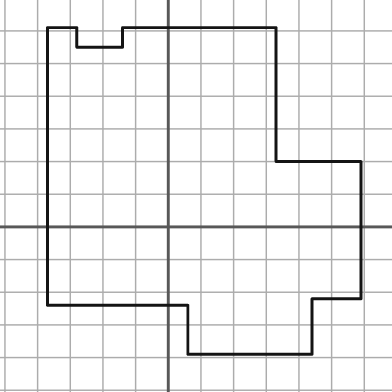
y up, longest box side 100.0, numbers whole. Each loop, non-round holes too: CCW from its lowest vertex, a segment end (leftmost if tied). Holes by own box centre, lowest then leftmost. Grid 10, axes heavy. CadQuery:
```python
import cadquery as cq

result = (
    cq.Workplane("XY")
    .moveTo(6.0, -39.0)
    .lineTo(44.0, -39.0)
    .lineTo(44.0, -22.0)
    .lineTo(59.0, -22.0)
    .lineTo(59.0, 20.0)
    .lineTo(33.0, 20.0)
    .lineTo(33.0, 61.0)
    .lineTo(-14.0, 61.0)
    .lineTo(-14.0, 55.0)
    .lineTo(-28.0, 55.0)
    .lineTo(-28.0, 61.0)
    .lineTo(-37.0, 61.0)
    .lineTo(-37.0, -24.0)
    .lineTo(6.0, -24.0)
    .close()
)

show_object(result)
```